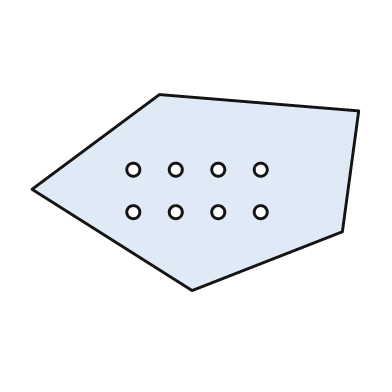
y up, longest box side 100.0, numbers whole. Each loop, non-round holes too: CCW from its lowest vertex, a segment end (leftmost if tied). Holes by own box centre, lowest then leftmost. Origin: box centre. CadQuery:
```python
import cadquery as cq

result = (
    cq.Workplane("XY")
    .moveTo(-1.0, -30.0)
    .lineTo(45.0, -12.0)
    .lineTo(50.0, 25.0)
    .lineTo(-11.0, 30.0)
    .lineTo(-50.0, 1.0)
    .close()
    .moveTo(-19.0, -6.0)
    .circle(2.0)
    .moveTo(-6.0, -6.0)
    .circle(2.0)
    .moveTo(7.0, -6.0)
    .circle(2.0)
    .moveTo(20.0, -6.0)
    .circle(2.0)
    .moveTo(-19.0, 7.0)
    .circle(2.0)
    .moveTo(-6.0, 7.0)
    .circle(2.0)
    .moveTo(7.0, 7.0)
    .circle(2.0)
    .moveTo(20.0, 7.0)
    .circle(2.0)
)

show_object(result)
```